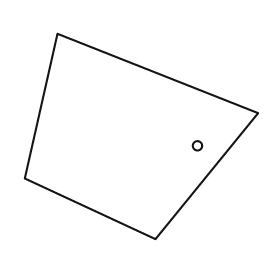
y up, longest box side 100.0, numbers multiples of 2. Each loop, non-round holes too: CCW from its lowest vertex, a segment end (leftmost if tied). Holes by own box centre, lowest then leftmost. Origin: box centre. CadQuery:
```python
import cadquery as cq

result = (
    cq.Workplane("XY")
    .moveTo(6.0, -44.0)
    .lineTo(50.0, 10.0)
    .lineTo(-36.0, 44.0)
    .lineTo(-50.0, -18.0)
    .close()
    .moveTo(24.0, -4.0)
    .circle(2.0)
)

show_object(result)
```